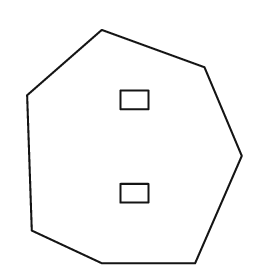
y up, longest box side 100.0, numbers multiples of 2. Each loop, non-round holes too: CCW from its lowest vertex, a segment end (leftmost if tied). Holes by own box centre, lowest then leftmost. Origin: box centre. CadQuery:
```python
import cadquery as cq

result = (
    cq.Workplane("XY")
    .moveTo(-14.0, -50.0)
    .lineTo(26.0, -50.0)
    .lineTo(46.0, -4.0)
    .lineTo(30.0, 34.0)
    .lineTo(-14.0, 50.0)
    .lineTo(-46.0, 22.0)
    .lineTo(-44.0, -36.0)
    .close()
    .moveTo(-6.0, -24.0)
    .lineTo(6.0, -24.0)
    .lineTo(6.0, -16.0)
    .lineTo(-6.0, -16.0)
    .close()
    .moveTo(-6.0, 16.0)
    .lineTo(6.0, 16.0)
    .lineTo(6.0, 24.0)
    .lineTo(-6.0, 24.0)
    .close()
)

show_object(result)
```